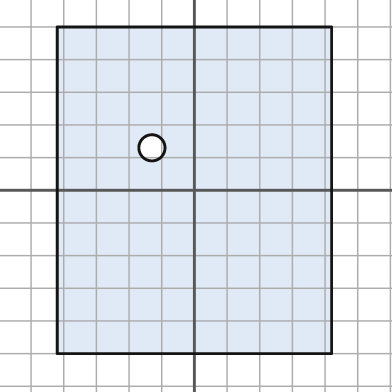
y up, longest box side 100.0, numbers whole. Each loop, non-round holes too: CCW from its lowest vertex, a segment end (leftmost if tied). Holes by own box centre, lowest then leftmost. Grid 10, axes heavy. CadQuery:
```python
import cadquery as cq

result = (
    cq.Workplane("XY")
    .moveTo(-42.0, -50.0)
    .lineTo(42.0, -50.0)
    .lineTo(42.0, 50.0)
    .lineTo(-42.0, 50.0)
    .close()
    .moveTo(-13.0, 13.0)
    .circle(4.0)
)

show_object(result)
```